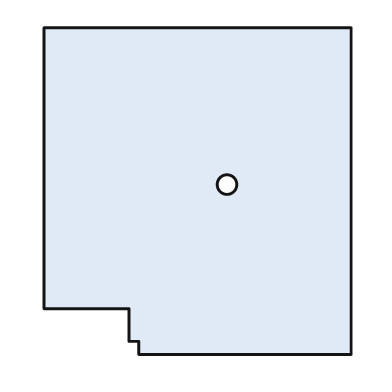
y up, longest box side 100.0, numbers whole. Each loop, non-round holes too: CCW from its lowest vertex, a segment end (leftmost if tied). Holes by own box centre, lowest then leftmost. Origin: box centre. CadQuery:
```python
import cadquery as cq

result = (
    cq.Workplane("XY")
    .moveTo(-18.0, -50.0)
    .lineTo(47.0, -50.0)
    .lineTo(47.0, 50.0)
    .lineTo(-47.0, 50.0)
    .lineTo(-47.0, -36.0)
    .lineTo(-21.0, -36.0)
    .lineTo(-21.0, -46.0)
    .lineTo(-18.0, -46.0)
    .close()
    .moveTo(9.0, 2.0)
    .circle(3.0)
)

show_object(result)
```